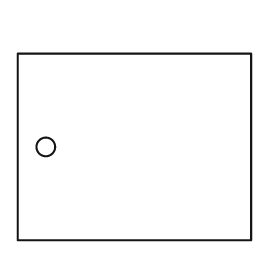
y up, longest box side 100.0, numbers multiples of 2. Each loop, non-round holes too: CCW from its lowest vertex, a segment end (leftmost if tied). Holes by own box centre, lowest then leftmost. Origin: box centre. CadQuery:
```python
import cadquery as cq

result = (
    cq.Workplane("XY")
    .moveTo(-50.0, -40.0)
    .lineTo(50.0, -40.0)
    .lineTo(50.0, 40.0)
    .lineTo(-50.0, 40.0)
    .close()
    .moveTo(-38.0, 0.0)
    .circle(4.0)
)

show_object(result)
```